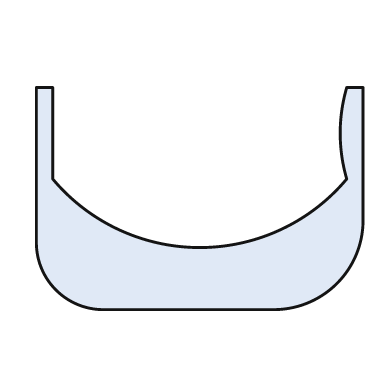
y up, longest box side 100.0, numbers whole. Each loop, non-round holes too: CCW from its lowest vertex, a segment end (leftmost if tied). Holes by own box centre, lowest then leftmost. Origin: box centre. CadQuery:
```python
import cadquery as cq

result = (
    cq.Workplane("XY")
    .moveTo(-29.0, -34.0)
    .lineTo(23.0, -34.0)
    .threePointArc((42.0, -26.0), (50.0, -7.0))
    .lineTo(50.0, 34.0)
    .lineTo(45.0, 34.0)
    .threePointArc((43.0, 20.0), (45.0, 6.0))
    .threePointArc((0.0, -15.0), (-45.0, 6.0))
    .lineTo(-45.0, 34.0)
    .lineTo(-50.0, 34.0)
    .lineTo(-50.0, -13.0)
    .threePointArc((-44.0, -28.0), (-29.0, -34.0))
    .close()
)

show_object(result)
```